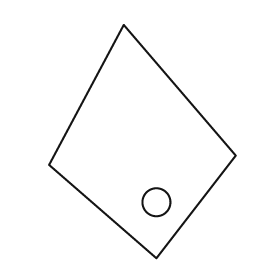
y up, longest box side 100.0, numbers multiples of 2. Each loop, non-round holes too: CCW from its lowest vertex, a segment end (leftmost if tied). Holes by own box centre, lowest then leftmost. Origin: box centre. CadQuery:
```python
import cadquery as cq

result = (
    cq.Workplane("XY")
    .moveTo(6.0, -50.0)
    .lineTo(40.0, -6.0)
    .lineTo(-8.0, 50.0)
    .lineTo(-40.0, -10.0)
    .close()
    .moveTo(6.0, -26.0)
    .circle(6.0)
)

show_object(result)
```